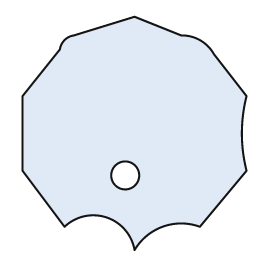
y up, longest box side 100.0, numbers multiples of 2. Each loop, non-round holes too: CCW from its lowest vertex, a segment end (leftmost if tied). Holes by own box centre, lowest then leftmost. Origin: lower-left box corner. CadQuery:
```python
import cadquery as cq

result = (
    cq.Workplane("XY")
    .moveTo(48.0, 0.0)
    .threePointArc((60.0, 10.0), (76.0, 10.0))
    .lineTo(96.0, 34.0)
    .threePointArc((94.0, 50.0), (96.0, 66.0))
    .lineTo(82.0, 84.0)
    .threePointArc((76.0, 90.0), (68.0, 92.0))
    .lineTo(48.0, 100.0)
    .lineTo(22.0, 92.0)
    .threePointArc((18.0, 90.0), (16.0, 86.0))
    .lineTo(0.0, 66.0)
    .lineTo(0.0, 34.0)
    .lineTo(18.0, 10.0)
    .threePointArc((36.0, 14.0), (48.0, 0.0))
    .close()
    .moveTo(44.0, 32.0)
    .circle(6.0)
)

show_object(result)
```